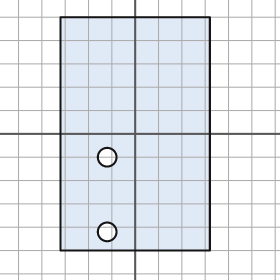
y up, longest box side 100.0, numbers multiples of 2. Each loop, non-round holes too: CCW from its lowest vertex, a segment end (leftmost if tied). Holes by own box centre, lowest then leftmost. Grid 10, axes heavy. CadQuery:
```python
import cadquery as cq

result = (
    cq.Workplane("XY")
    .moveTo(-32.0, -50.0)
    .lineTo(32.0, -50.0)
    .lineTo(32.0, 50.0)
    .lineTo(-32.0, 50.0)
    .close()
    .moveTo(-12.0, -42.0)
    .circle(4.0)
    .moveTo(-12.0, -10.0)
    .circle(4.0)
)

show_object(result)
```